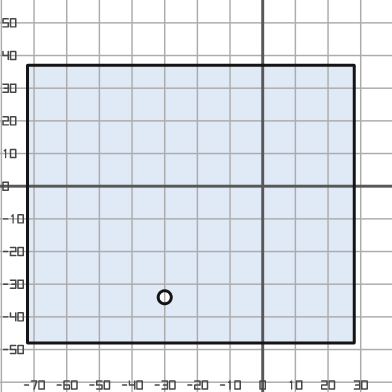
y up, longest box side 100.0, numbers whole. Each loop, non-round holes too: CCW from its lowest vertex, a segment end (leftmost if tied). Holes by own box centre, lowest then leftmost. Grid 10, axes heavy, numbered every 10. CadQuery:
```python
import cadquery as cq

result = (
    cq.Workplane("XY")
    .moveTo(-72.0, -48.0)
    .lineTo(28.0, -48.0)
    .lineTo(28.0, 37.0)
    .lineTo(-72.0, 37.0)
    .close()
    .moveTo(-30.0, -34.0)
    .circle(2.0)
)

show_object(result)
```